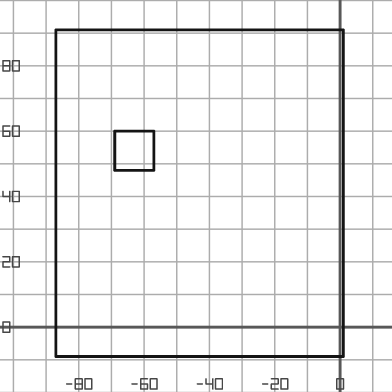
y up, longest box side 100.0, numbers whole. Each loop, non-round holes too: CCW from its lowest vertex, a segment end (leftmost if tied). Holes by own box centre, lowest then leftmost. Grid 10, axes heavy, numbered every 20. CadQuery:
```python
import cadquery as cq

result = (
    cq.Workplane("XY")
    .moveTo(-87.0, -9.0)
    .lineTo(1.0, -9.0)
    .lineTo(1.0, 91.0)
    .lineTo(-87.0, 91.0)
    .close()
    .moveTo(-69.0, 48.0)
    .lineTo(-57.0, 48.0)
    .lineTo(-57.0, 60.0)
    .lineTo(-69.0, 60.0)
    .close()
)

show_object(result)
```